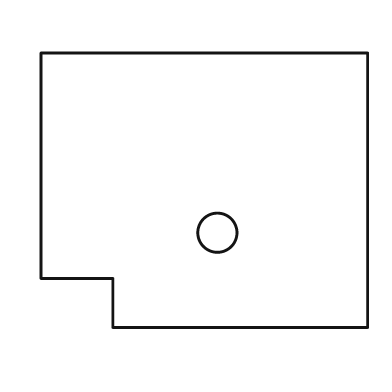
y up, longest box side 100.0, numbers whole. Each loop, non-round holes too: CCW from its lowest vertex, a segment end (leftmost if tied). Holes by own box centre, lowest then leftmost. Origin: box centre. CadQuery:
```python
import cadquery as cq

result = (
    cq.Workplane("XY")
    .moveTo(-28.0, -42.0)
    .lineTo(50.0, -42.0)
    .lineTo(50.0, 42.0)
    .lineTo(-50.0, 42.0)
    .lineTo(-50.0, -27.0)
    .lineTo(-28.0, -27.0)
    .close()
    .moveTo(4.0, -13.0)
    .circle(6.0)
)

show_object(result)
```